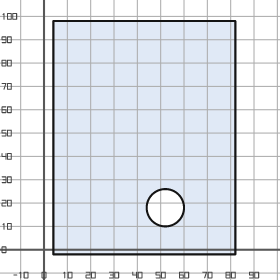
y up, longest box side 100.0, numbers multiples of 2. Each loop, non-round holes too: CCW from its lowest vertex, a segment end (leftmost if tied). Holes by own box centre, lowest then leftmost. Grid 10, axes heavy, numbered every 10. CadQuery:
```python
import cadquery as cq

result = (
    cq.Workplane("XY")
    .moveTo(4.0, -2.0)
    .lineTo(82.0, -2.0)
    .lineTo(82.0, 98.0)
    .lineTo(4.0, 98.0)
    .close()
    .moveTo(52.0, 18.0)
    .circle(8.0)
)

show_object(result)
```